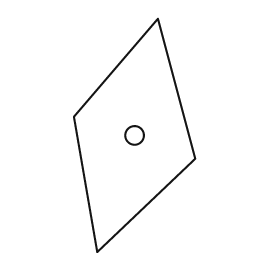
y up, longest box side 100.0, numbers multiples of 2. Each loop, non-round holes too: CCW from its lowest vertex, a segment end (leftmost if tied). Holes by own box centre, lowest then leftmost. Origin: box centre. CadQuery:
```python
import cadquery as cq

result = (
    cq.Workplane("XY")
    .moveTo(-16.0, -50.0)
    .lineTo(26.0, -10.0)
    .lineTo(10.0, 50.0)
    .lineTo(-26.0, 8.0)
    .close()
    .moveTo(0.0, 0.0)
    .circle(4.0)
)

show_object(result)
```